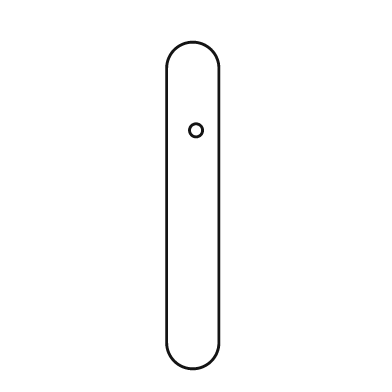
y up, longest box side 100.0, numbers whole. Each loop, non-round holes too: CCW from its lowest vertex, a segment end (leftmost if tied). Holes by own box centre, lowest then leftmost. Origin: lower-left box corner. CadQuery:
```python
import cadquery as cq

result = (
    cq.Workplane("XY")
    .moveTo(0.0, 8.0)
    .threePointArc((8.0, 0.0), (16.0, 8.0))
    .lineTo(16.0, 92.0)
    .threePointArc((8.0, 100.0), (0.0, 92.0))
    .close()
    .moveTo(9.0, 73.0)
    .circle(2.0)
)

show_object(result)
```